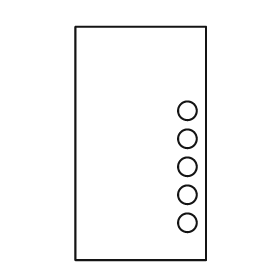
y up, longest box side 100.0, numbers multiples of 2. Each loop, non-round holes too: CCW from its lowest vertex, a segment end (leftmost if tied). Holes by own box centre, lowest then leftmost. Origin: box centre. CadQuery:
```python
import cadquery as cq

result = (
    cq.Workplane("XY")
    .moveTo(-28.0, -50.0)
    .lineTo(28.0, -50.0)
    .lineTo(28.0, 50.0)
    .lineTo(-28.0, 50.0)
    .close()
    .moveTo(20.0, -34.0)
    .circle(4.0)
    .moveTo(20.0, -22.0)
    .circle(4.0)
    .moveTo(20.0, -10.0)
    .circle(4.0)
    .moveTo(20.0, 2.0)
    .circle(4.0)
    .moveTo(20.0, 14.0)
    .circle(4.0)
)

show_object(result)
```